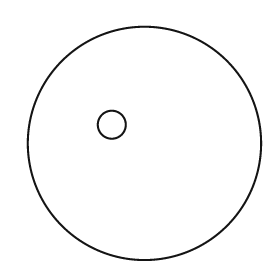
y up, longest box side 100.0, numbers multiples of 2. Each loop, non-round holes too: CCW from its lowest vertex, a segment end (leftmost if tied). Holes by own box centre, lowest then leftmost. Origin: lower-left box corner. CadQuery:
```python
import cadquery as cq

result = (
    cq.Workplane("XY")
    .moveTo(50.0, 50.0)
    .circle(50.0)
    .moveTo(36.0, 58.0)
    .circle(6.0)
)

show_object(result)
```